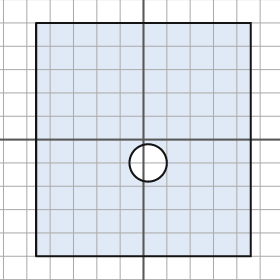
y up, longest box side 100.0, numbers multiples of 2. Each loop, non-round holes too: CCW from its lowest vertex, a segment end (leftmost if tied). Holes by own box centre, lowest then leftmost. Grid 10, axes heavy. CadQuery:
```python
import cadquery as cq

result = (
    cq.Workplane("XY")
    .moveTo(-46.0, -50.0)
    .lineTo(46.0, -50.0)
    .lineTo(46.0, 50.0)
    .lineTo(-46.0, 50.0)
    .close()
    .moveTo(2.0, -10.0)
    .circle(8.0)
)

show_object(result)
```